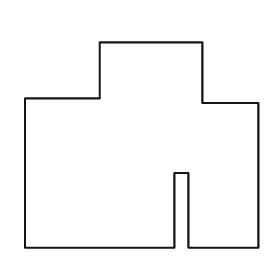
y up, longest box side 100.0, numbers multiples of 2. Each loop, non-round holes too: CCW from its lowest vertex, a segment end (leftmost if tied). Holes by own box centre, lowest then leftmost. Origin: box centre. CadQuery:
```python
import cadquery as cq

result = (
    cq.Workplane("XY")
    .moveTo(-50.0, -44.0)
    .lineTo(14.0, -44.0)
    .lineTo(14.0, -12.0)
    .lineTo(20.0, -12.0)
    .lineTo(20.0, -44.0)
    .lineTo(50.0, -44.0)
    .lineTo(50.0, 18.0)
    .lineTo(26.0, 18.0)
    .lineTo(26.0, 44.0)
    .lineTo(-18.0, 44.0)
    .lineTo(-18.0, 20.0)
    .lineTo(-50.0, 20.0)
    .close()
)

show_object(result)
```